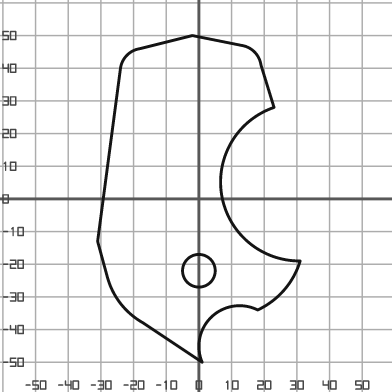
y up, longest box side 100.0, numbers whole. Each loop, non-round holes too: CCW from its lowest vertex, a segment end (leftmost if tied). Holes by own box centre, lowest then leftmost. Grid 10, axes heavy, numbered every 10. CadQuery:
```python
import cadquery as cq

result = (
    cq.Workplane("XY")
    .moveTo(1.0, -50.0)
    .threePointArc((4.0, -36.0), (18.0, -34.0))
    .threePointArc((26.0, -28.0), (31.0, -19.0))
    .threePointArc((7.0, 1.0), (23.0, 28.0))
    .lineTo(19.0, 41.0)
    .threePointArc((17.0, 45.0), (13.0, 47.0))
    .lineTo(-2.0, 50.0)
    .lineTo(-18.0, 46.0)
    .threePointArc((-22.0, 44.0), (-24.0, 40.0))
    .lineTo(-31.0, -13.0)
    .lineTo(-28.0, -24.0)
    .threePointArc((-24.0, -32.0), (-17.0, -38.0))
    .close()
    .moveTo(0.0, -22.0)
    .circle(5.0)
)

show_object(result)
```